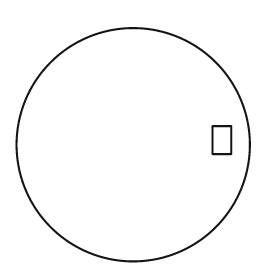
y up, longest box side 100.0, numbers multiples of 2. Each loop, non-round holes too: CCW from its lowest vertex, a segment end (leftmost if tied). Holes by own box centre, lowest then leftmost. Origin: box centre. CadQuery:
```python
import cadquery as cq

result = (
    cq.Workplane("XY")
    .moveTo(0.0, 0.0)
    .circle(50.0)
    .moveTo(34.0, -4.0)
    .lineTo(42.0, -4.0)
    .lineTo(42.0, 8.0)
    .lineTo(34.0, 8.0)
    .close()
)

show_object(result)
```